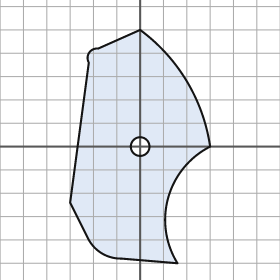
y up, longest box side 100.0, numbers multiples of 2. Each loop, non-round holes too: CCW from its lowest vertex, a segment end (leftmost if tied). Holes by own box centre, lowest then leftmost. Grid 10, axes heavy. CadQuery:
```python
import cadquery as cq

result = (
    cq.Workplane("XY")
    .moveTo(16.0, -50.0)
    .threePointArc((12.0, -22.0), (30.0, 0.0))
    .threePointArc((20.0, 28.0), (0.0, 50.0))
    .lineTo(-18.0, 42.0)
    .threePointArc((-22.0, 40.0), (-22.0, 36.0))
    .lineTo(-30.0, -24.0)
    .lineTo(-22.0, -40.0)
    .threePointArc((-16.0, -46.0), (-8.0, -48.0))
    .close()
    .moveTo(0.0, 0.0)
    .circle(4.0)
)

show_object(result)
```